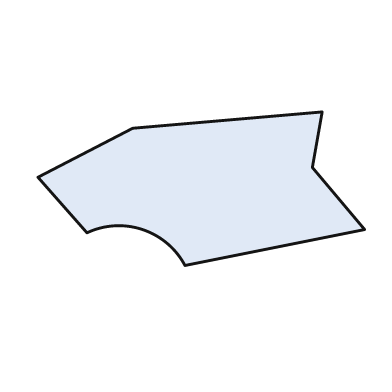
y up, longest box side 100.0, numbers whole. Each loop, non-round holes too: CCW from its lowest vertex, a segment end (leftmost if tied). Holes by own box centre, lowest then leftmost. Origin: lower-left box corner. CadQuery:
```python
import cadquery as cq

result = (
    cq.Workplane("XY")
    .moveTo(45.0, 0.0)
    .lineTo(100.0, 11.0)
    .lineTo(84.0, 30.0)
    .lineTo(87.0, 47.0)
    .lineTo(29.0, 42.0)
    .lineTo(0.0, 27.0)
    .lineTo(15.0, 10.0)
    .threePointArc((32.0, 11.0), (45.0, 0.0))
    .close()
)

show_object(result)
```